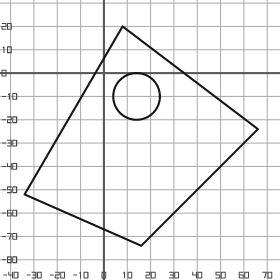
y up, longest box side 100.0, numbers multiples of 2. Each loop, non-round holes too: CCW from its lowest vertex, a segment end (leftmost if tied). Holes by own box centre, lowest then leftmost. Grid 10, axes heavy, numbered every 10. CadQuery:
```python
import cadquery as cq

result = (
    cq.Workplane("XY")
    .moveTo(16.0, -74.0)
    .lineTo(66.0, -24.0)
    .lineTo(8.0, 20.0)
    .lineTo(-34.0, -52.0)
    .close()
    .moveTo(14.0, -10.0)
    .circle(10.0)
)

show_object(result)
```